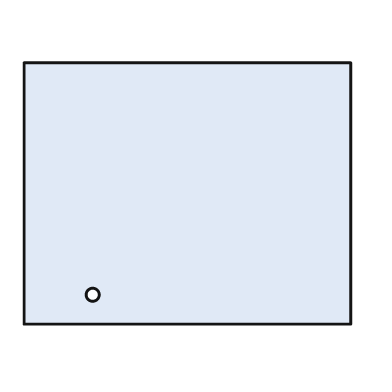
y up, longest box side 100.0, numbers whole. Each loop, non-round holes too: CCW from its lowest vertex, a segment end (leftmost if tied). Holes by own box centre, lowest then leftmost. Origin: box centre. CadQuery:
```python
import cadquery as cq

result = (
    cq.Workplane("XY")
    .moveTo(-50.0, -40.0)
    .lineTo(50.0, -40.0)
    .lineTo(50.0, 40.0)
    .lineTo(-50.0, 40.0)
    .close()
    .moveTo(-29.0, -31.0)
    .circle(2.0)
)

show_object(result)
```